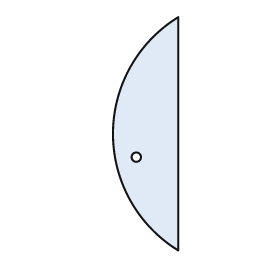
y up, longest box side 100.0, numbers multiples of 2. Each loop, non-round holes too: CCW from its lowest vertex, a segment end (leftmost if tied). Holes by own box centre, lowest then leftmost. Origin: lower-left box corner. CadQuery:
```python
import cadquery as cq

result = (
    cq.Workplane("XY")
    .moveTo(28.0, 0.0)
    .lineTo(28.0, 100.0)
    .threePointArc((0.0, 50.0), (28.0, 0.0))
    .close()
    .moveTo(10.0, 40.0)
    .circle(2.0)
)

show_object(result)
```